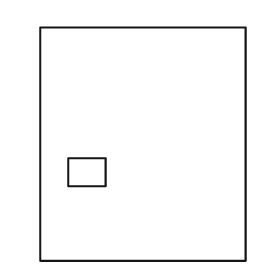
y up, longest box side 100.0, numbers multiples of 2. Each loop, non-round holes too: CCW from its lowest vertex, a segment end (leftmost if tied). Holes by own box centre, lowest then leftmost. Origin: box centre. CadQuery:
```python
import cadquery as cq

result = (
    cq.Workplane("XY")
    .moveTo(-44.0, -50.0)
    .lineTo(44.0, -50.0)
    .lineTo(44.0, 50.0)
    .lineTo(-44.0, 50.0)
    .close()
    .moveTo(-32.0, -18.0)
    .lineTo(-16.0, -18.0)
    .lineTo(-16.0, -6.0)
    .lineTo(-32.0, -6.0)
    .close()
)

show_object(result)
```